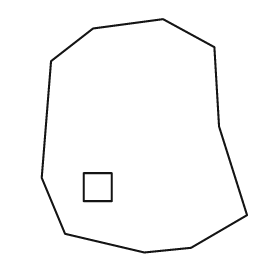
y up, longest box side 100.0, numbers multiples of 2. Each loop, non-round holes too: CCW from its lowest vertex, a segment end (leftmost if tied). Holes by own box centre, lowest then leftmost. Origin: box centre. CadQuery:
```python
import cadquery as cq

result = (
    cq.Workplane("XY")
    .moveTo(0.0, -50.0)
    .lineTo(20.0, -48.0)
    .lineTo(44.0, -34.0)
    .lineTo(32.0, 4.0)
    .lineTo(30.0, 38.0)
    .lineTo(8.0, 50.0)
    .lineTo(-22.0, 46.0)
    .lineTo(-40.0, 32.0)
    .lineTo(-44.0, -18.0)
    .lineTo(-34.0, -42.0)
    .close()
    .moveTo(-26.0, -28.0)
    .lineTo(-14.0, -28.0)
    .lineTo(-14.0, -16.0)
    .lineTo(-26.0, -16.0)
    .close()
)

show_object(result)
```